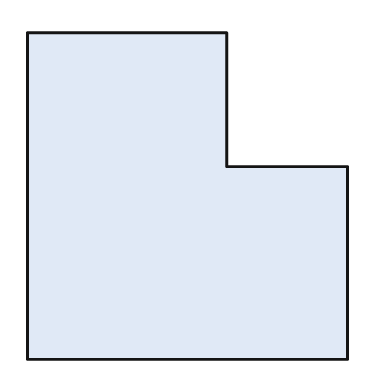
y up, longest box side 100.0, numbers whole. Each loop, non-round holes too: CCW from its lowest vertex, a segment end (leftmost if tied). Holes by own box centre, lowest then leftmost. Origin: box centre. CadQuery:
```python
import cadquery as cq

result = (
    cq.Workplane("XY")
    .moveTo(-49.0, -50.0)
    .lineTo(49.0, -50.0)
    .lineTo(49.0, 9.0)
    .lineTo(12.0, 9.0)
    .lineTo(12.0, 50.0)
    .lineTo(-49.0, 50.0)
    .close()
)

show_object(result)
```